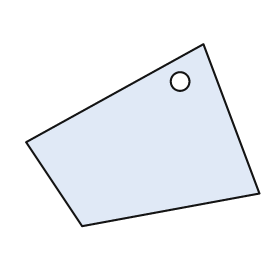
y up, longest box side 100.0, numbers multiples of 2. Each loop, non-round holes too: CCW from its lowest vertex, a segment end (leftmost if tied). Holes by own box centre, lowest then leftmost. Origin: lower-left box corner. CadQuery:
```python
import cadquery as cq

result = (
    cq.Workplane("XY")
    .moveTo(24.0, 0.0)
    .lineTo(100.0, 14.0)
    .lineTo(76.0, 78.0)
    .lineTo(0.0, 36.0)
    .close()
    .moveTo(66.0, 62.0)
    .circle(4.0)
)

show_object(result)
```